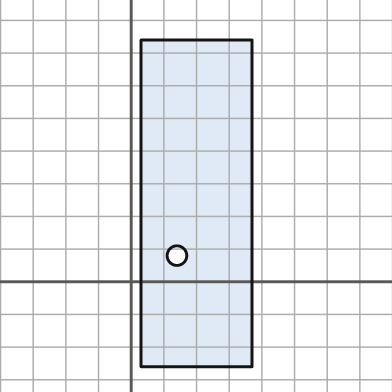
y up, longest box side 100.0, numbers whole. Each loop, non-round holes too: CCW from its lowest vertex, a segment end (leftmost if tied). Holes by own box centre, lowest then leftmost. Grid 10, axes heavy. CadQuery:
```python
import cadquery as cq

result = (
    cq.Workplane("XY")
    .moveTo(3.0, -26.0)
    .lineTo(37.0, -26.0)
    .lineTo(37.0, 74.0)
    .lineTo(3.0, 74.0)
    .close()
    .moveTo(14.0, 8.0)
    .circle(3.0)
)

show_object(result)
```